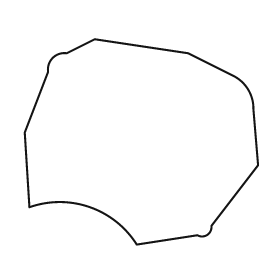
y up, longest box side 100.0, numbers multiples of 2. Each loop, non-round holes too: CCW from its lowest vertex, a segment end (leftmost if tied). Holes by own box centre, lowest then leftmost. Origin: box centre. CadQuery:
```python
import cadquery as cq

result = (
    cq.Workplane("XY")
    .moveTo(-2.0, -44.0)
    .lineTo(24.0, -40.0)
    .threePointArc((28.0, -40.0), (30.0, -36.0))
    .lineTo(50.0, -10.0)
    .lineTo(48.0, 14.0)
    .threePointArc((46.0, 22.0), (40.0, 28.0))
    .lineTo(20.0, 38.0)
    .lineTo(-20.0, 44.0)
    .lineTo(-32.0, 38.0)
    .threePointArc((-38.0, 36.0), (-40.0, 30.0))
    .lineTo(-50.0, 4.0)
    .lineTo(-48.0, -28.0)
    .threePointArc((-22.0, -28.0), (-2.0, -44.0))
    .close()
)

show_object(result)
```